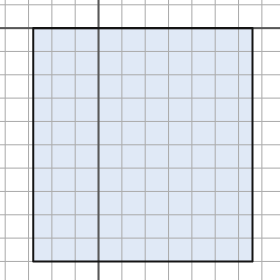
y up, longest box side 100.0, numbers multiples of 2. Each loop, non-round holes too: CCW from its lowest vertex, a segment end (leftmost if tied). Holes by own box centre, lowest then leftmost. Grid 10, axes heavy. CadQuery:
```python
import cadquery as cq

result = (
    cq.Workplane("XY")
    .moveTo(-28.0, -100.0)
    .lineTo(66.0, -100.0)
    .lineTo(66.0, 0.0)
    .lineTo(-28.0, 0.0)
    .close()
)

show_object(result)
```